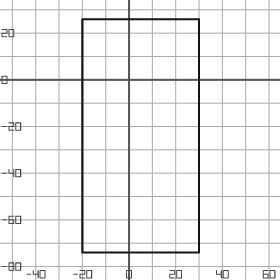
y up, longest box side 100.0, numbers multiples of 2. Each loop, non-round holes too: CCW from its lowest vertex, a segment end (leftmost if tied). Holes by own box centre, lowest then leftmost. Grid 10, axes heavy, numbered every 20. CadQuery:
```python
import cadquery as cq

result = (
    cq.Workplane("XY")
    .moveTo(-20.0, -74.0)
    .lineTo(30.0, -74.0)
    .lineTo(30.0, 26.0)
    .lineTo(-20.0, 26.0)
    .close()
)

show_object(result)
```